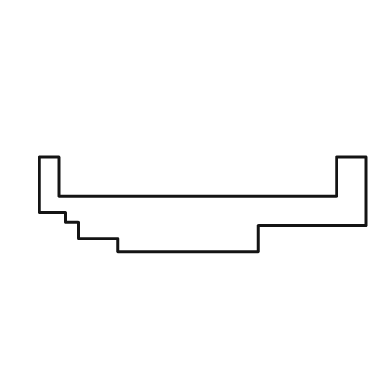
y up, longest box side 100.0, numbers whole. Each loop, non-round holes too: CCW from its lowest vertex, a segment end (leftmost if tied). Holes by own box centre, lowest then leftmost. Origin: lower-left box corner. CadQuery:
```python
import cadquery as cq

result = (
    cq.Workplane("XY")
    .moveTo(24.0, 0.0)
    .lineTo(67.0, 0.0)
    .lineTo(67.0, 8.0)
    .lineTo(100.0, 8.0)
    .lineTo(100.0, 29.0)
    .lineTo(91.0, 29.0)
    .lineTo(91.0, 17.0)
    .lineTo(6.0, 17.0)
    .lineTo(6.0, 29.0)
    .lineTo(0.0, 29.0)
    .lineTo(0.0, 12.0)
    .lineTo(8.0, 12.0)
    .lineTo(8.0, 9.0)
    .lineTo(12.0, 9.0)
    .lineTo(12.0, 4.0)
    .lineTo(24.0, 4.0)
    .close()
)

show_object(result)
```